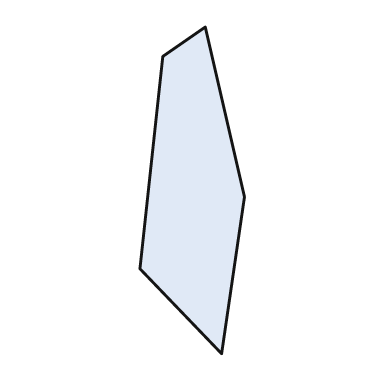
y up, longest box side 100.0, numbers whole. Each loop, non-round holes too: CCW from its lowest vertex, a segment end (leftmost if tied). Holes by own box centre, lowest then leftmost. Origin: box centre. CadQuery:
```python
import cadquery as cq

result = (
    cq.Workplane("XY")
    .moveTo(9.0, -50.0)
    .lineTo(16.0, -2.0)
    .lineTo(4.0, 50.0)
    .lineTo(-9.0, 41.0)
    .lineTo(-16.0, -24.0)
    .close()
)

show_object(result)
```